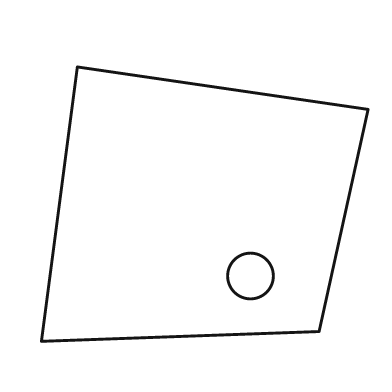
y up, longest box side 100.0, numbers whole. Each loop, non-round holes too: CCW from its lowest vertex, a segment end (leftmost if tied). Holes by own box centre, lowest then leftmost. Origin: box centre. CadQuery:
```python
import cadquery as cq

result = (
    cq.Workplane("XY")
    .moveTo(-50.0, -42.0)
    .lineTo(35.0, -39.0)
    .lineTo(50.0, 29.0)
    .lineTo(-39.0, 42.0)
    .close()
    .moveTo(14.0, -22.0)
    .circle(7.0)
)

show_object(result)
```